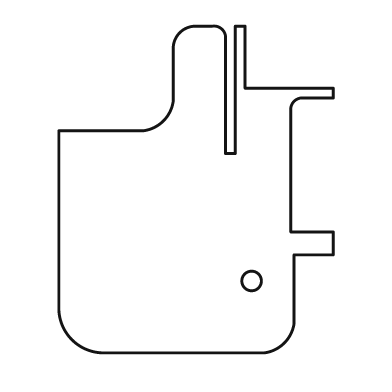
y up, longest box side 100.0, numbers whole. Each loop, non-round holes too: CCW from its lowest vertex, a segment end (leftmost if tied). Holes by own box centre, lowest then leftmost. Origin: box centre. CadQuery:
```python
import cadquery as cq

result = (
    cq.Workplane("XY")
    .moveTo(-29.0, -50.0)
    .lineTo(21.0, -50.0)
    .threePointArc((27.0, -47.0), (30.0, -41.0))
    .lineTo(30.0, -20.0)
    .lineTo(42.0, -20.0)
    .lineTo(42.0, -13.0)
    .lineTo(29.0, -13.0)
    .lineTo(29.0, 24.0)
    .threePointArc((30.0, 27.0), (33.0, 28.0))
    .lineTo(42.0, 28.0)
    .lineTo(42.0, 31.0)
    .lineTo(15.0, 31.0)
    .lineTo(15.0, 50.0)
    .lineTo(12.0, 50.0)
    .lineTo(12.0, 11.0)
    .lineTo(9.0, 11.0)
    .lineTo(9.0, 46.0)
    .threePointArc((8.0, 49.0), (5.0, 50.0))
    .lineTo(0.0, 50.0)
    .threePointArc((-5.0, 48.0), (-7.0, 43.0))
    .lineTo(-7.0, 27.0)
    .threePointArc((-10.0, 21.0), (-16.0, 18.0))
    .lineTo(-42.0, 18.0)
    .lineTo(-42.0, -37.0)
    .threePointArc((-38.0, -46.0), (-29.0, -50.0))
    .close()
    .moveTo(17.0, -28.0)
    .circle(3.0)
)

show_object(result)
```